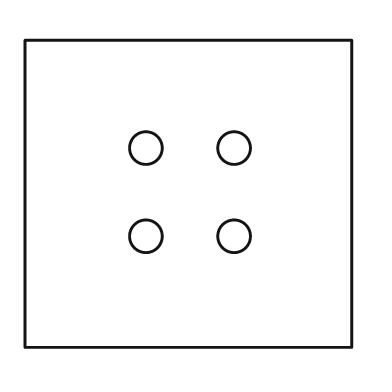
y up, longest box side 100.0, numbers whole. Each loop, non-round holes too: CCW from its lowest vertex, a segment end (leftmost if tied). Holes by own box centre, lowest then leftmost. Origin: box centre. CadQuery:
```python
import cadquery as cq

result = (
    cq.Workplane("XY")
    .moveTo(-50.0, -47.0)
    .lineTo(50.0, -47.0)
    .lineTo(50.0, 47.0)
    .lineTo(-50.0, 47.0)
    .close()
    .moveTo(-13.0, -13.0)
    .circle(5.0)
    .moveTo(14.0, -13.0)
    .circle(5.0)
    .moveTo(-13.0, 14.0)
    .circle(5.0)
    .moveTo(14.0, 14.0)
    .circle(5.0)
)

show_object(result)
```